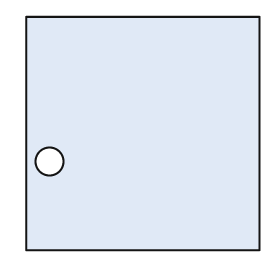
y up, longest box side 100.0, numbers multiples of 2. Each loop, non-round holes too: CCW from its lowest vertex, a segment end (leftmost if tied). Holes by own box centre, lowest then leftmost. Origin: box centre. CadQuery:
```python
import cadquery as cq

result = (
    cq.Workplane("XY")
    .moveTo(-50.0, -50.0)
    .lineTo(50.0, -50.0)
    .lineTo(50.0, 50.0)
    .lineTo(-50.0, 50.0)
    .close()
    .moveTo(-40.0, -12.0)
    .circle(6.0)
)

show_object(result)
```